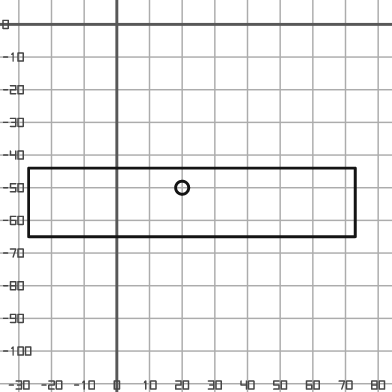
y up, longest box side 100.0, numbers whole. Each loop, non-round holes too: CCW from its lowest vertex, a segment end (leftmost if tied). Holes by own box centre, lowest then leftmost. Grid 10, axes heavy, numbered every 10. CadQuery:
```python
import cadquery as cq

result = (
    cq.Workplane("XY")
    .moveTo(-27.0, -65.0)
    .lineTo(73.0, -65.0)
    .lineTo(73.0, -44.0)
    .lineTo(-27.0, -44.0)
    .close()
    .moveTo(20.0, -50.0)
    .circle(2.0)
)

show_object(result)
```